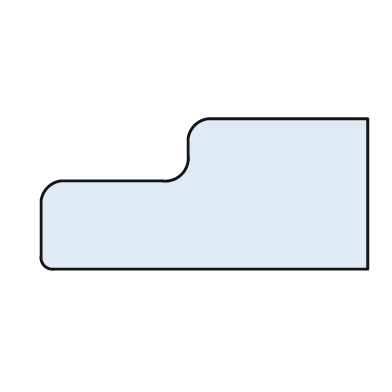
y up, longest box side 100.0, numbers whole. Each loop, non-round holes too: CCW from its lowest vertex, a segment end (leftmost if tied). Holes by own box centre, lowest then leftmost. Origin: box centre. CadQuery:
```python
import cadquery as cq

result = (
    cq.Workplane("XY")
    .moveTo(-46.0, -23.0)
    .lineTo(50.0, -23.0)
    .lineTo(50.0, 23.0)
    .lineTo(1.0, 23.0)
    .threePointArc((-3.0, 21.0), (-5.0, 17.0))
    .lineTo(-5.0, 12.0)
    .threePointArc((-7.0, 6.0), (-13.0, 4.0))
    .lineTo(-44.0, 4.0)
    .threePointArc((-48.0, 2.0), (-50.0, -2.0))
    .lineTo(-50.0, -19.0)
    .threePointArc((-49.0, -22.0), (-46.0, -23.0))
    .close()
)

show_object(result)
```